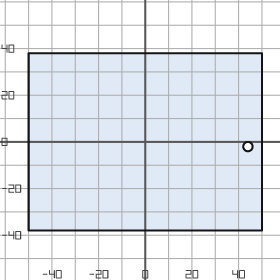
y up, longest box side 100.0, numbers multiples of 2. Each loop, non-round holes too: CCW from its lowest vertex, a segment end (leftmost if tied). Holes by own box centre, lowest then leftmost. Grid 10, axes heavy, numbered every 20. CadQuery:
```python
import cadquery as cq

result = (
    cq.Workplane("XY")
    .moveTo(-50.0, -38.0)
    .lineTo(50.0, -38.0)
    .lineTo(50.0, 38.0)
    .lineTo(-50.0, 38.0)
    .close()
    .moveTo(44.0, -2.0)
    .circle(2.0)
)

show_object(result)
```